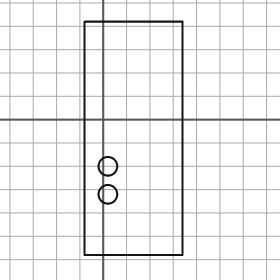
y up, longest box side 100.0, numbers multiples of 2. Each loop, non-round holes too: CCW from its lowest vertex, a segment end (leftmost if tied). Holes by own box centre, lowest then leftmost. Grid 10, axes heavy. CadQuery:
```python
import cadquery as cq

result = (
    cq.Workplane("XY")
    .moveTo(-8.0, -58.0)
    .lineTo(34.0, -58.0)
    .lineTo(34.0, 42.0)
    .lineTo(-8.0, 42.0)
    .close()
    .moveTo(2.0, -32.0)
    .circle(4.0)
    .moveTo(2.0, -20.0)
    .circle(4.0)
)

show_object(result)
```